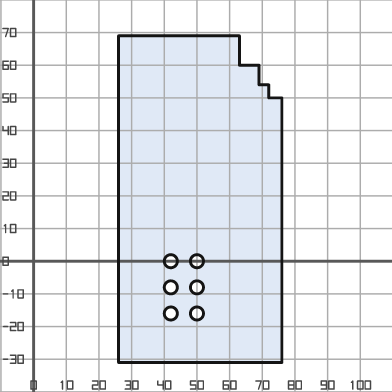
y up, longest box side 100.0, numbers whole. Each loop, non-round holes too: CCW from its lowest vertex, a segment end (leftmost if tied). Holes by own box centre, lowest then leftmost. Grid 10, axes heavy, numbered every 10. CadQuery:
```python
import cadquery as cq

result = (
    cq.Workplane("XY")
    .moveTo(26.0, -31.0)
    .lineTo(76.0, -31.0)
    .lineTo(76.0, 50.0)
    .lineTo(72.0, 50.0)
    .lineTo(72.0, 54.0)
    .lineTo(69.0, 54.0)
    .lineTo(69.0, 60.0)
    .lineTo(63.0, 60.0)
    .lineTo(63.0, 69.0)
    .lineTo(26.0, 69.0)
    .close()
    .moveTo(42.0, -16.0)
    .circle(2.0)
    .moveTo(50.0, -16.0)
    .circle(2.0)
    .moveTo(42.0, -8.0)
    .circle(2.0)
    .moveTo(50.0, -8.0)
    .circle(2.0)
    .moveTo(42.0, 0.0)
    .circle(2.0)
    .moveTo(50.0, 0.0)
    .circle(2.0)
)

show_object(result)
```